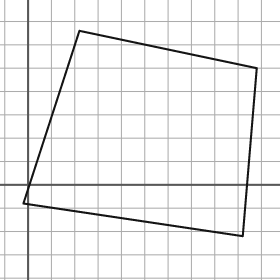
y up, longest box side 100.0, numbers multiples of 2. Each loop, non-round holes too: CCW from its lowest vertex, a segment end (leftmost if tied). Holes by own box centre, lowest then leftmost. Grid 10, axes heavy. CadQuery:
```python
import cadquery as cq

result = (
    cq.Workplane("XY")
    .moveTo(92.0, -22.0)
    .lineTo(98.0, 50.0)
    .lineTo(22.0, 66.0)
    .lineTo(-2.0, -8.0)
    .close()
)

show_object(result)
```